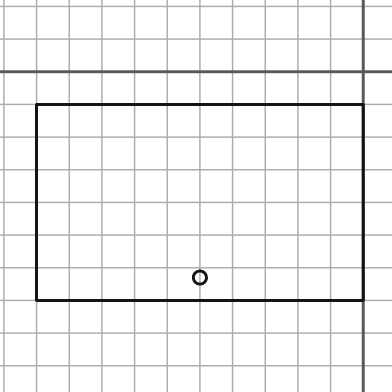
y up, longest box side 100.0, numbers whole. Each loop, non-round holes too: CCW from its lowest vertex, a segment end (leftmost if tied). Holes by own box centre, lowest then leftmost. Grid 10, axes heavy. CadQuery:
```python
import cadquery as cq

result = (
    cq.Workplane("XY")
    .moveTo(-100.0, -70.0)
    .lineTo(0.0, -70.0)
    .lineTo(0.0, -10.0)
    .lineTo(-100.0, -10.0)
    .close()
    .moveTo(-50.0, -63.0)
    .circle(2.0)
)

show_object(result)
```